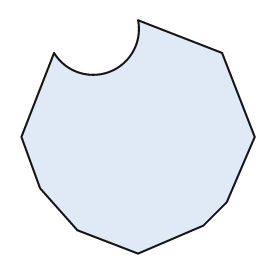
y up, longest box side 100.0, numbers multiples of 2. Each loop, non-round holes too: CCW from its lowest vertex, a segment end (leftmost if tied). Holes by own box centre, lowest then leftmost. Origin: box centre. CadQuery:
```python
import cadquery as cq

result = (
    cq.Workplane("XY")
    .moveTo(0.0, -50.0)
    .lineTo(28.0, -38.0)
    .lineTo(38.0, -28.0)
    .lineTo(50.0, 0.0)
    .lineTo(36.0, 36.0)
    .lineTo(0.0, 50.0)
    .threePointArc((-12.0, 28.0), (-36.0, 36.0))
    .lineTo(-50.0, 0.0)
    .lineTo(-42.0, -22.0)
    .lineTo(-26.0, -40.0)
    .close()
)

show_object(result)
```